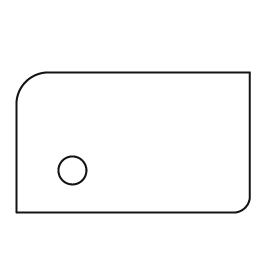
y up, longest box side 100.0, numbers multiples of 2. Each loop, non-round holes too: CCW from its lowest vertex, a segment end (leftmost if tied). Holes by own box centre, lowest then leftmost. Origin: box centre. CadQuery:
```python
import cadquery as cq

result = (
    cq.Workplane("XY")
    .moveTo(-50.0, -30.0)
    .lineTo(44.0, -30.0)
    .threePointArc((48.0, -28.0), (50.0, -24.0))
    .lineTo(50.0, 30.0)
    .lineTo(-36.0, 30.0)
    .threePointArc((-46.0, 26.0), (-50.0, 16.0))
    .close()
    .moveTo(-26.0, -12.0)
    .circle(6.0)
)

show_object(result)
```